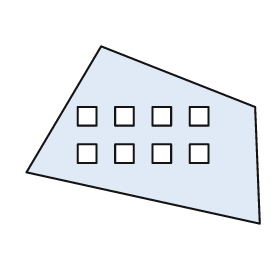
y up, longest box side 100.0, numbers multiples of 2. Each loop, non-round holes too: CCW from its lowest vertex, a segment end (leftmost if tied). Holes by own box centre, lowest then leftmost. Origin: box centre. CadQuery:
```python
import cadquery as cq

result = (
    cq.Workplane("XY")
    .moveTo(50.0, -38.0)
    .lineTo(48.0, 12.0)
    .lineTo(-18.0, 38.0)
    .lineTo(-50.0, -16.0)
    .close()
    .moveTo(-28.0, -12.0)
    .lineTo(-20.0, -12.0)
    .lineTo(-20.0, -4.0)
    .lineTo(-28.0, -4.0)
    .close()
    .moveTo(-12.0, -12.0)
    .lineTo(-4.0, -12.0)
    .lineTo(-4.0, -4.0)
    .lineTo(-12.0, -4.0)
    .close()
    .moveTo(4.0, -12.0)
    .lineTo(12.0, -12.0)
    .lineTo(12.0, -4.0)
    .lineTo(4.0, -4.0)
    .close()
    .moveTo(20.0, -12.0)
    .lineTo(28.0, -12.0)
    .lineTo(28.0, -4.0)
    .lineTo(20.0, -4.0)
    .close()
    .moveTo(-28.0, 4.0)
    .lineTo(-20.0, 4.0)
    .lineTo(-20.0, 12.0)
    .lineTo(-28.0, 12.0)
    .close()
    .moveTo(-12.0, 4.0)
    .lineTo(-4.0, 4.0)
    .lineTo(-4.0, 12.0)
    .lineTo(-12.0, 12.0)
    .close()
    .moveTo(4.0, 4.0)
    .lineTo(12.0, 4.0)
    .lineTo(12.0, 12.0)
    .lineTo(4.0, 12.0)
    .close()
    .moveTo(20.0, 4.0)
    .lineTo(28.0, 4.0)
    .lineTo(28.0, 12.0)
    .lineTo(20.0, 12.0)
    .close()
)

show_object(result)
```